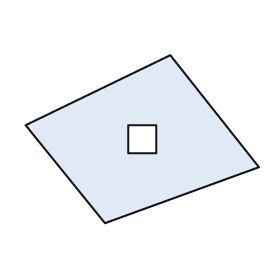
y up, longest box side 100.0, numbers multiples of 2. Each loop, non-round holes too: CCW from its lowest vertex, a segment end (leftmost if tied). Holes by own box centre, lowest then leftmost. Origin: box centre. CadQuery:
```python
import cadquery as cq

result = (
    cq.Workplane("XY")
    .moveTo(-16.0, -36.0)
    .lineTo(50.0, -12.0)
    .lineTo(12.0, 36.0)
    .lineTo(-50.0, 6.0)
    .close()
    .moveTo(-6.0, -6.0)
    .lineTo(6.0, -6.0)
    .lineTo(6.0, 6.0)
    .lineTo(-6.0, 6.0)
    .close()
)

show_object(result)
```